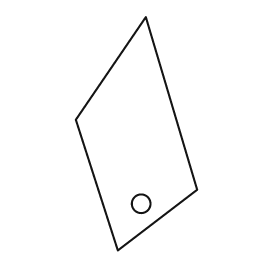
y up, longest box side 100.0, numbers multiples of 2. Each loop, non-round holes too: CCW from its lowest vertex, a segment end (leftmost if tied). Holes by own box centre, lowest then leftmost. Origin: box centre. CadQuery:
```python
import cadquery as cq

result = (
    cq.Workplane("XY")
    .moveTo(-8.0, -50.0)
    .lineTo(26.0, -24.0)
    .lineTo(4.0, 50.0)
    .lineTo(-26.0, 6.0)
    .close()
    .moveTo(2.0, -30.0)
    .circle(4.0)
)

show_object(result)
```